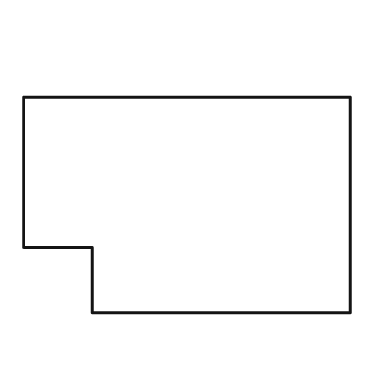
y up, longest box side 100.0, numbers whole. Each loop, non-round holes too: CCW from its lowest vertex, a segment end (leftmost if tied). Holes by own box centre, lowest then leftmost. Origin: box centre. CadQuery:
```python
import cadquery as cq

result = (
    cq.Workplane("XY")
    .moveTo(-29.0, -33.0)
    .lineTo(50.0, -33.0)
    .lineTo(50.0, 33.0)
    .lineTo(-50.0, 33.0)
    .lineTo(-50.0, -13.0)
    .lineTo(-29.0, -13.0)
    .close()
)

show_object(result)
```